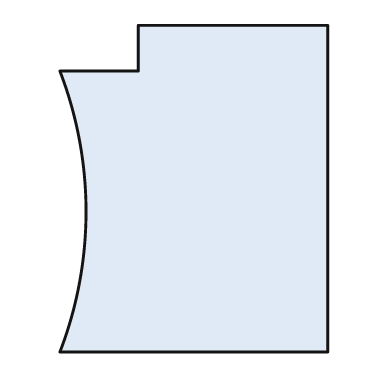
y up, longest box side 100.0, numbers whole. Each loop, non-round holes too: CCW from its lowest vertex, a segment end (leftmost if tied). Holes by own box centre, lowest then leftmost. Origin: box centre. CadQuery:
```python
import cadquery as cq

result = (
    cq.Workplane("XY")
    .moveTo(-41.0, -50.0)
    .lineTo(41.0, -50.0)
    .lineTo(41.0, 50.0)
    .lineTo(-17.0, 50.0)
    .lineTo(-17.0, 36.0)
    .lineTo(-41.0, 36.0)
    .threePointArc((-33.0, -7.0), (-41.0, -50.0))
    .close()
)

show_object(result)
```